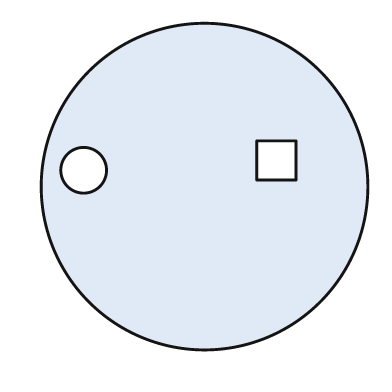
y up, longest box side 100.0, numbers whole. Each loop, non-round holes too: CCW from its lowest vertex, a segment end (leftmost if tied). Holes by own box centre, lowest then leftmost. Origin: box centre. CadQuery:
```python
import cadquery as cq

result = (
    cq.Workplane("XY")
    .moveTo(0.0, 0.0)
    .circle(50.0)
    .moveTo(-37.0, 5.0)
    .circle(7.0)
    .moveTo(16.0, 2.0)
    .lineTo(28.0, 2.0)
    .lineTo(28.0, 14.0)
    .lineTo(16.0, 14.0)
    .close()
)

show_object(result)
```